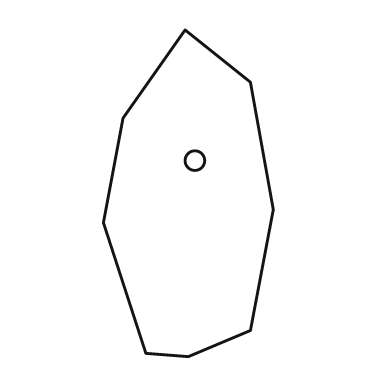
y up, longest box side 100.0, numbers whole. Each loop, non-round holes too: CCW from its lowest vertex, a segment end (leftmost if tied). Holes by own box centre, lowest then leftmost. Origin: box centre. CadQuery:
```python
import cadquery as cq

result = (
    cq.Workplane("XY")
    .moveTo(0.0, -50.0)
    .lineTo(19.0, -42.0)
    .lineTo(26.0, -5.0)
    .lineTo(19.0, 34.0)
    .lineTo(-1.0, 50.0)
    .lineTo(-20.0, 23.0)
    .lineTo(-26.0, -9.0)
    .lineTo(-13.0, -49.0)
    .close()
    .moveTo(2.0, 10.0)
    .circle(3.0)
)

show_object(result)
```